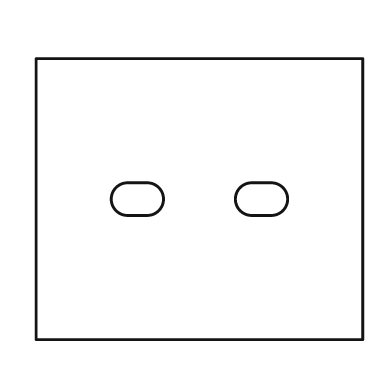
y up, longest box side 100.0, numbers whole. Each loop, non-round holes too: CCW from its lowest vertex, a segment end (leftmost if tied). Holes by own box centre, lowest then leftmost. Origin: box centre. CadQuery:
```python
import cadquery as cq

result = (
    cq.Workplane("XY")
    .moveTo(-50.0, -43.0)
    .lineTo(50.0, -43.0)
    .lineTo(50.0, 43.0)
    .lineTo(-50.0, 43.0)
    .close()
    .moveTo(-22.0, -5.0)
    .lineTo(-16.0, -5.0)
    .threePointArc((-11.0, 0.0), (-16.0, 5.0))
    .lineTo(-22.0, 5.0)
    .threePointArc((-27.0, 0.0), (-22.0, -5.0))
    .close()
    .moveTo(16.0, -5.0)
    .lineTo(22.0, -5.0)
    .threePointArc((27.0, 0.0), (22.0, 5.0))
    .lineTo(16.0, 5.0)
    .threePointArc((11.0, 0.0), (16.0, -5.0))
    .close()
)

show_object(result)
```